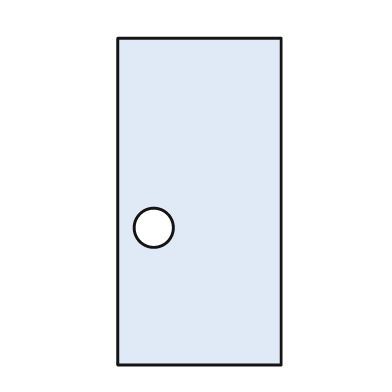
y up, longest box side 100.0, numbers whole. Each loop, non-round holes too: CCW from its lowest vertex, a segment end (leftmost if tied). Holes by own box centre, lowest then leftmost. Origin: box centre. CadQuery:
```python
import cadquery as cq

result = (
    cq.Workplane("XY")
    .moveTo(-25.0, -50.0)
    .lineTo(25.0, -50.0)
    .lineTo(25.0, 50.0)
    .lineTo(-25.0, 50.0)
    .close()
    .moveTo(-14.0, -8.0)
    .circle(6.0)
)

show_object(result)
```